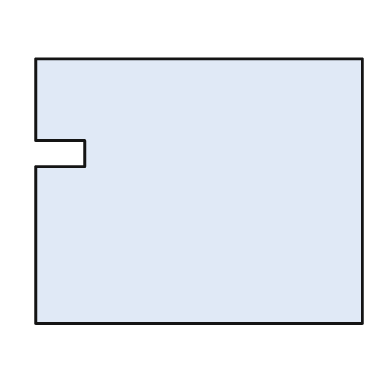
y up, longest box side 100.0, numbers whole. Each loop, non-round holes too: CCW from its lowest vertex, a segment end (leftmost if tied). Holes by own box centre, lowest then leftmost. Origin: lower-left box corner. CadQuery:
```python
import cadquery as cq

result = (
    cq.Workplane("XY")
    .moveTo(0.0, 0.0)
    .lineTo(100.0, 0.0)
    .lineTo(100.0, 81.0)
    .lineTo(0.0, 81.0)
    .lineTo(0.0, 56.0)
    .lineTo(15.0, 56.0)
    .lineTo(15.0, 48.0)
    .lineTo(0.0, 48.0)
    .close()
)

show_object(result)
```